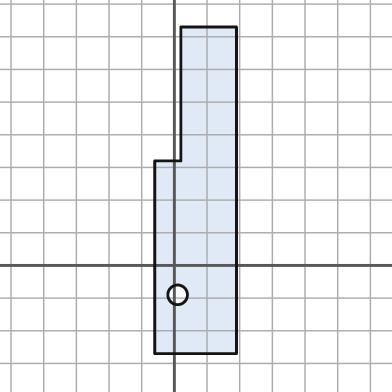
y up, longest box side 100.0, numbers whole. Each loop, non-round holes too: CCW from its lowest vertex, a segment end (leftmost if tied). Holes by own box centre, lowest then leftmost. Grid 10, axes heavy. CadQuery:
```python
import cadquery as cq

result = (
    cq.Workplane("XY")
    .moveTo(-6.0, -27.0)
    .lineTo(19.0, -27.0)
    .lineTo(19.0, 73.0)
    .lineTo(2.0, 73.0)
    .lineTo(2.0, 32.0)
    .lineTo(-6.0, 32.0)
    .close()
    .moveTo(1.0, -9.0)
    .circle(3.0)
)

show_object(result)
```